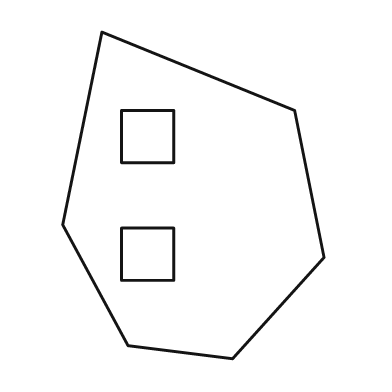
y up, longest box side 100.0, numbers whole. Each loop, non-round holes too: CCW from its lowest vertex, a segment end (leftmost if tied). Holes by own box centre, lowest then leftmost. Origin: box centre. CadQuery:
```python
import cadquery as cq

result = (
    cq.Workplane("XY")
    .moveTo(12.0, -50.0)
    .lineTo(40.0, -19.0)
    .lineTo(31.0, 26.0)
    .lineTo(-28.0, 50.0)
    .lineTo(-40.0, -9.0)
    .lineTo(-20.0, -46.0)
    .close()
    .moveTo(-22.0, -26.0)
    .lineTo(-6.0, -26.0)
    .lineTo(-6.0, -10.0)
    .lineTo(-22.0, -10.0)
    .close()
    .moveTo(-22.0, 10.0)
    .lineTo(-6.0, 10.0)
    .lineTo(-6.0, 26.0)
    .lineTo(-22.0, 26.0)
    .close()
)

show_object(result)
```